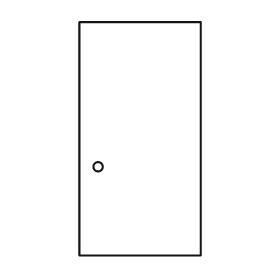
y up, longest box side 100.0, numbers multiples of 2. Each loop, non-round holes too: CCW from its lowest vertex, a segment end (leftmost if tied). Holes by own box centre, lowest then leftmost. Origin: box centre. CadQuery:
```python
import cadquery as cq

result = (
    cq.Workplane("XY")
    .moveTo(-26.0, -50.0)
    .lineTo(26.0, -50.0)
    .lineTo(26.0, 50.0)
    .lineTo(-26.0, 50.0)
    .close()
    .moveTo(-18.0, -12.0)
    .circle(2.0)
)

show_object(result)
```